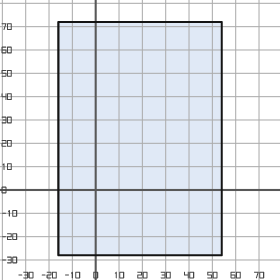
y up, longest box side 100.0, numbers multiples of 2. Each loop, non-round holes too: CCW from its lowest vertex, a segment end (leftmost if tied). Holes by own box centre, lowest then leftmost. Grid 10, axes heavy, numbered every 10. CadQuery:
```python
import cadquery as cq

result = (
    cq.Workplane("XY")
    .moveTo(-16.0, -28.0)
    .lineTo(54.0, -28.0)
    .lineTo(54.0, 72.0)
    .lineTo(-16.0, 72.0)
    .close()
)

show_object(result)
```